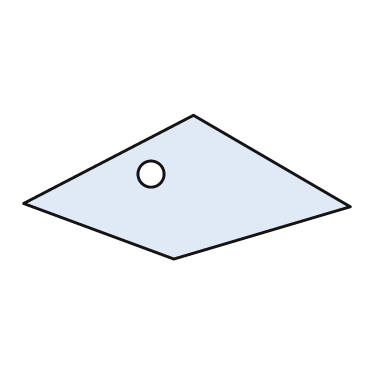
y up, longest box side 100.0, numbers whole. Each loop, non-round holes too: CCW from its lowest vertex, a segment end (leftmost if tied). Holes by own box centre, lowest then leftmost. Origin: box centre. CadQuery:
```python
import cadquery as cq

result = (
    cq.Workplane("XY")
    .moveTo(-4.0, -22.0)
    .lineTo(50.0, -6.0)
    .lineTo(2.0, 22.0)
    .lineTo(-50.0, -5.0)
    .close()
    .moveTo(-11.0, 4.0)
    .circle(4.0)
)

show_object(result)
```